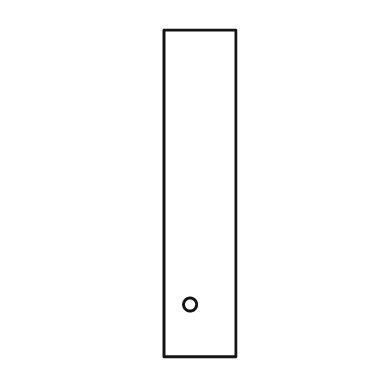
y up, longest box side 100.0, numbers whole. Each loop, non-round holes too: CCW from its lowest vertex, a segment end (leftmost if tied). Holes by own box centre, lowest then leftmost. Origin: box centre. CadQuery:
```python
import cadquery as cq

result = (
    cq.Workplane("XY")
    .moveTo(-11.0, -50.0)
    .lineTo(11.0, -50.0)
    .lineTo(11.0, 50.0)
    .lineTo(-11.0, 50.0)
    .close()
    .moveTo(-3.0, -34.0)
    .circle(2.0)
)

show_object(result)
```